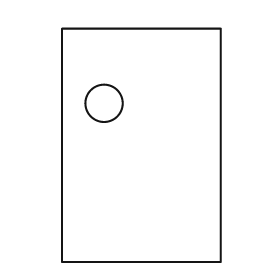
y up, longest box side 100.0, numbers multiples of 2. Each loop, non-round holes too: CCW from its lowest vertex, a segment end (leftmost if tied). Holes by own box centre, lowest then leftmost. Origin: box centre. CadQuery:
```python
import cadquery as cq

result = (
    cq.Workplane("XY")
    .moveTo(-34.0, -50.0)
    .lineTo(34.0, -50.0)
    .lineTo(34.0, 50.0)
    .lineTo(-34.0, 50.0)
    .close()
    .moveTo(-16.0, 18.0)
    .circle(8.0)
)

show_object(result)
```